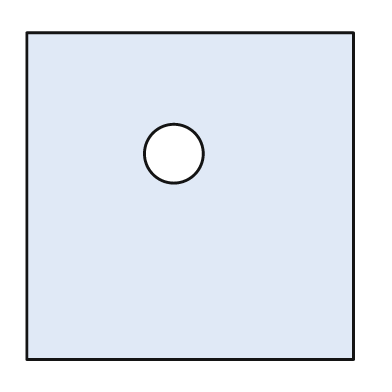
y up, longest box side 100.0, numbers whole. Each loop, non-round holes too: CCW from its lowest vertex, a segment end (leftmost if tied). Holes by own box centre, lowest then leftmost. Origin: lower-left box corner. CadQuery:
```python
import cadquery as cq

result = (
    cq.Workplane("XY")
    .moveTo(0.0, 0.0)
    .lineTo(100.0, 0.0)
    .lineTo(100.0, 100.0)
    .lineTo(0.0, 100.0)
    .close()
    .moveTo(45.0, 63.0)
    .circle(9.0)
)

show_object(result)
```